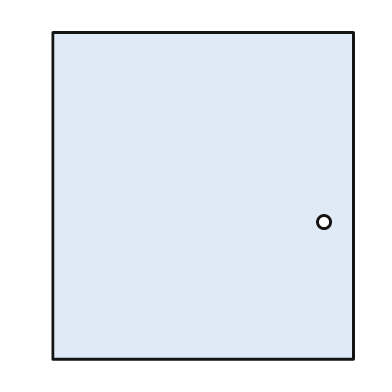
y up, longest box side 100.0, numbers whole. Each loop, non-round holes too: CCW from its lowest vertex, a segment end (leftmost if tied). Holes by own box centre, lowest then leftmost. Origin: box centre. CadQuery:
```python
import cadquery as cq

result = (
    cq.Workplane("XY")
    .moveTo(-46.0, -50.0)
    .lineTo(46.0, -50.0)
    .lineTo(46.0, 50.0)
    .lineTo(-46.0, 50.0)
    .close()
    .moveTo(37.0, -8.0)
    .circle(2.0)
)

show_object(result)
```